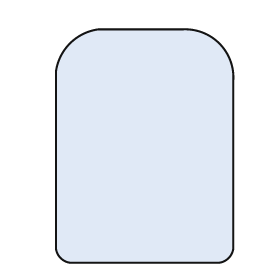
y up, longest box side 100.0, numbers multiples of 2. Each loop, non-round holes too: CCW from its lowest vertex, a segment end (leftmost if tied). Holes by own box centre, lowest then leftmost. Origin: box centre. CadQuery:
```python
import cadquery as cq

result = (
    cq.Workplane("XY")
    .moveTo(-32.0, -50.0)
    .lineTo(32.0, -50.0)
    .threePointArc((36.0, -48.0), (38.0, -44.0))
    .lineTo(38.0, 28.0)
    .threePointArc((32.0, 44.0), (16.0, 50.0))
    .lineTo(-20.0, 50.0)
    .threePointArc((-32.0, 44.0), (-38.0, 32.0))
    .lineTo(-38.0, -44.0)
    .threePointArc((-36.0, -48.0), (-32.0, -50.0))
    .close()
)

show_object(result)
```